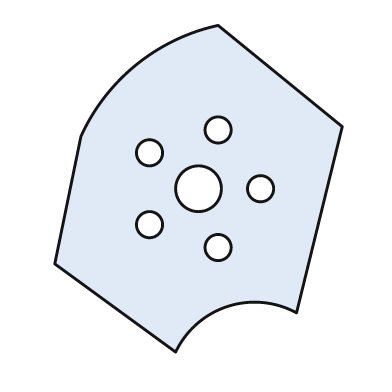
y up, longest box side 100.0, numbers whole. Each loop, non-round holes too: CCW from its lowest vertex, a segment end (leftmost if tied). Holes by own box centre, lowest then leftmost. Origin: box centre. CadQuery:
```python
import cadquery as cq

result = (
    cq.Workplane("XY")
    .moveTo(-7.0, -50.0)
    .threePointArc((9.0, -36.0), (30.0, -38.0))
    .lineTo(44.0, 19.0)
    .lineTo(6.0, 50.0)
    .threePointArc((-19.0, 38.0), (-36.0, 16.0))
    .lineTo(-44.0, -23.0)
    .close()
    .moveTo(6.0, -18.0)
    .circle(4.0)
    .moveTo(-15.0, -11.0)
    .circle(4.0)
    .moveTo(0.0, 0.0)
    .circle(7.0)
    .moveTo(19.0, 0.0)
    .circle(4.0)
    .moveTo(-15.0, 11.0)
    .circle(4.0)
    .moveTo(6.0, 18.0)
    .circle(4.0)
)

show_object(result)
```